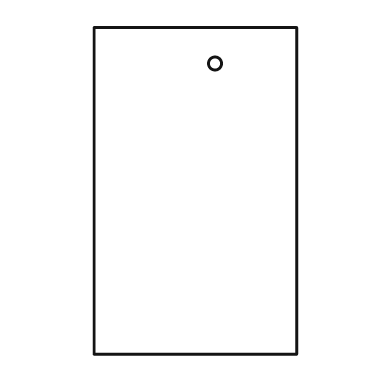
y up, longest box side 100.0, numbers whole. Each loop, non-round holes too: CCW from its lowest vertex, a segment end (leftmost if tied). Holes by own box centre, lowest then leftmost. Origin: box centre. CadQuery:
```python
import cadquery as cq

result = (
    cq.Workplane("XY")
    .moveTo(-31.0, -50.0)
    .lineTo(31.0, -50.0)
    .lineTo(31.0, 50.0)
    .lineTo(-31.0, 50.0)
    .close()
    .moveTo(6.0, 39.0)
    .circle(2.0)
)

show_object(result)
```